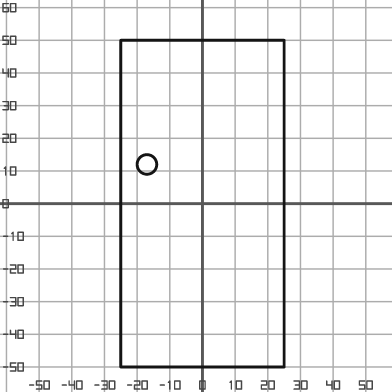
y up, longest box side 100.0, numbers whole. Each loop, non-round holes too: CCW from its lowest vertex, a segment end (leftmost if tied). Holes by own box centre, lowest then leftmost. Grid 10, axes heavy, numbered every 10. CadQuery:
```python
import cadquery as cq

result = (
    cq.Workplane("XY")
    .moveTo(-25.0, -50.0)
    .lineTo(25.0, -50.0)
    .lineTo(25.0, 50.0)
    .lineTo(-25.0, 50.0)
    .close()
    .moveTo(-17.0, 12.0)
    .circle(3.0)
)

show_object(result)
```